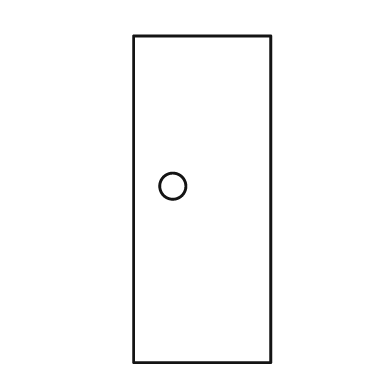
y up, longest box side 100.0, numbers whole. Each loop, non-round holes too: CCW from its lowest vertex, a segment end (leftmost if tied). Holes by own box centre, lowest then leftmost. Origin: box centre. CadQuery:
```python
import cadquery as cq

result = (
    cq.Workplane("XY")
    .moveTo(-21.0, -50.0)
    .lineTo(21.0, -50.0)
    .lineTo(21.0, 50.0)
    .lineTo(-21.0, 50.0)
    .close()
    .moveTo(-9.0, 4.0)
    .circle(4.0)
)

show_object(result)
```